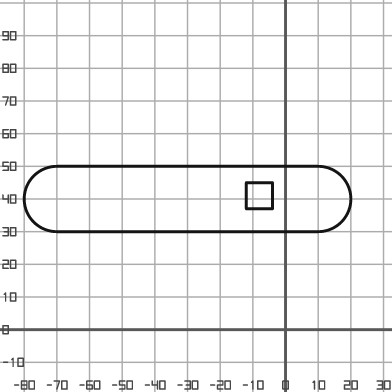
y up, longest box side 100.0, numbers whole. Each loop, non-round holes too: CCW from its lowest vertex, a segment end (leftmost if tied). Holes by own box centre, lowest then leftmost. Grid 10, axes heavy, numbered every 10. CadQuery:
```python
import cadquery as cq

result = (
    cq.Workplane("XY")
    .moveTo(-70.0, 30.0)
    .lineTo(10.0, 30.0)
    .threePointArc((20.0, 40.0), (10.0, 50.0))
    .lineTo(-70.0, 50.0)
    .threePointArc((-80.0, 40.0), (-70.0, 30.0))
    .close()
    .moveTo(-12.0, 37.0)
    .lineTo(-4.0, 37.0)
    .lineTo(-4.0, 45.0)
    .lineTo(-12.0, 45.0)
    .close()
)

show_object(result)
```